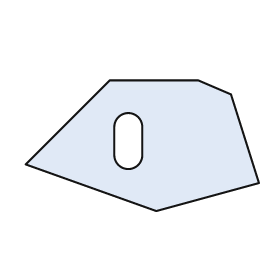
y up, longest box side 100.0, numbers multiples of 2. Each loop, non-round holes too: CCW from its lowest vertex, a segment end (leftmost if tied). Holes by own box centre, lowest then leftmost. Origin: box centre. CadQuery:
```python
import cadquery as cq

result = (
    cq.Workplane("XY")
    .moveTo(6.0, -28.0)
    .lineTo(50.0, -16.0)
    .lineTo(38.0, 22.0)
    .lineTo(24.0, 28.0)
    .lineTo(-14.0, 28.0)
    .lineTo(-50.0, -8.0)
    .close()
    .moveTo(-12.0, -4.0)
    .threePointArc((-6.0, -10.0), (0.0, -4.0))
    .lineTo(0.0, 8.0)
    .threePointArc((-6.0, 14.0), (-12.0, 8.0))
    .close()
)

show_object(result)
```